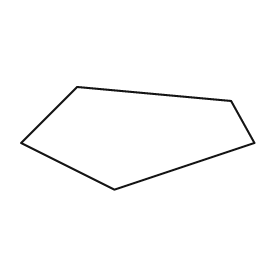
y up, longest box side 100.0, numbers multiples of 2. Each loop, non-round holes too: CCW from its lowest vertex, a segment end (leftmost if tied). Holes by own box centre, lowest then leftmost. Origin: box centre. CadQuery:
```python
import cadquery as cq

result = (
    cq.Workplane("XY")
    .moveTo(-10.0, -22.0)
    .lineTo(50.0, -2.0)
    .lineTo(40.0, 16.0)
    .lineTo(-26.0, 22.0)
    .lineTo(-50.0, -2.0)
    .close()
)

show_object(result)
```